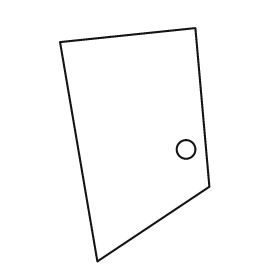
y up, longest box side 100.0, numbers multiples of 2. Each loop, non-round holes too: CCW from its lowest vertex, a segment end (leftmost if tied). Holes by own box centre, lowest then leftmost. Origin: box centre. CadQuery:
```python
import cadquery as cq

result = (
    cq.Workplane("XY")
    .moveTo(-16.0, -50.0)
    .lineTo(32.0, -18.0)
    .lineTo(26.0, 50.0)
    .lineTo(-32.0, 44.0)
    .close()
    .moveTo(22.0, -2.0)
    .circle(4.0)
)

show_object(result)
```